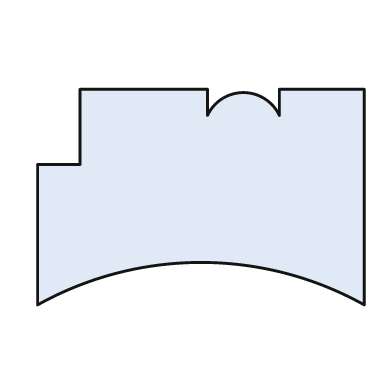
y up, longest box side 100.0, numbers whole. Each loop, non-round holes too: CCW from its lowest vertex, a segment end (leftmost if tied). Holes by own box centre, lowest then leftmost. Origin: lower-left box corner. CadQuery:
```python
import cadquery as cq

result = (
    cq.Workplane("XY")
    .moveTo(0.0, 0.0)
    .threePointArc((50.0, 13.0), (100.0, 0.0))
    .lineTo(100.0, 66.0)
    .lineTo(74.0, 66.0)
    .lineTo(74.0, 58.0)
    .threePointArc((63.0, 65.0), (52.0, 58.0))
    .lineTo(52.0, 66.0)
    .lineTo(13.0, 66.0)
    .lineTo(13.0, 43.0)
    .lineTo(0.0, 43.0)
    .close()
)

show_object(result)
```